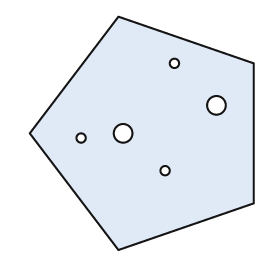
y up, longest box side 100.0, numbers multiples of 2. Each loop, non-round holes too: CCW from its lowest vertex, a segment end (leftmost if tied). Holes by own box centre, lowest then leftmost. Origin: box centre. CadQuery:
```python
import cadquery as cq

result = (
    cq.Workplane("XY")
    .moveTo(-10.0, -50.0)
    .lineTo(48.0, -30.0)
    .lineTo(48.0, 30.0)
    .lineTo(-10.0, 50.0)
    .lineTo(-48.0, 0.0)
    .close()
    .moveTo(10.0, -16.0)
    .circle(2.0)
    .moveTo(-26.0, -2.0)
    .circle(2.0)
    .moveTo(-8.0, 0.0)
    .circle(4.0)
    .moveTo(32.0, 12.0)
    .circle(4.0)
    .moveTo(14.0, 30.0)
    .circle(2.0)
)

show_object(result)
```